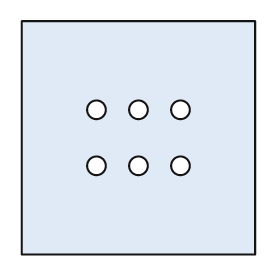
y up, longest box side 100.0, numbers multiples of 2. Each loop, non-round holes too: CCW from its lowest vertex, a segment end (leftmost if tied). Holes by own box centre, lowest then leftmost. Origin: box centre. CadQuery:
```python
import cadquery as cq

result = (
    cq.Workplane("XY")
    .moveTo(-50.0, -50.0)
    .lineTo(50.0, -50.0)
    .lineTo(50.0, 50.0)
    .lineTo(-50.0, 50.0)
    .close()
    .moveTo(-18.0, -12.0)
    .circle(4.0)
    .moveTo(0.0, -12.0)
    .circle(4.0)
    .moveTo(18.0, -12.0)
    .circle(4.0)
    .moveTo(-18.0, 12.0)
    .circle(4.0)
    .moveTo(0.0, 12.0)
    .circle(4.0)
    .moveTo(18.0, 12.0)
    .circle(4.0)
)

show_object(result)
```